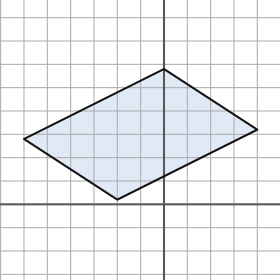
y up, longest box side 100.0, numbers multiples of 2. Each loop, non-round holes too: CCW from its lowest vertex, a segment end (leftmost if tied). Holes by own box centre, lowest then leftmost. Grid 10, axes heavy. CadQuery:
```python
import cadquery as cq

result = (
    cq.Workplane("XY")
    .moveTo(-20.0, 2.0)
    .lineTo(40.0, 32.0)
    .lineTo(0.0, 58.0)
    .lineTo(-60.0, 28.0)
    .close()
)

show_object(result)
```